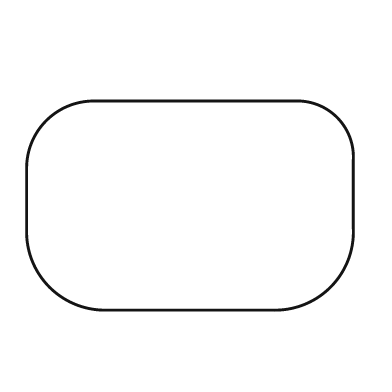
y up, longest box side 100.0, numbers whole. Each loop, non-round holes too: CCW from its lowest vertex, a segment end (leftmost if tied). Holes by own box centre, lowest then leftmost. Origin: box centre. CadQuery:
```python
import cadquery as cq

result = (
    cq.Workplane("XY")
    .moveTo(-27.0, -32.0)
    .lineTo(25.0, -32.0)
    .threePointArc((43.0, -25.0), (50.0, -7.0))
    .lineTo(50.0, 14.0)
    .threePointArc((45.0, 27.0), (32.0, 32.0))
    .lineTo(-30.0, 32.0)
    .threePointArc((-44.0, 26.0), (-50.0, 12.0))
    .lineTo(-50.0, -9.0)
    .threePointArc((-43.0, -25.0), (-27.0, -32.0))
    .close()
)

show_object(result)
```